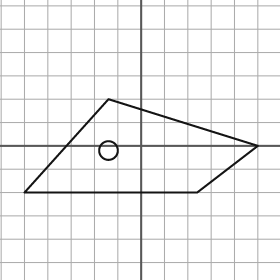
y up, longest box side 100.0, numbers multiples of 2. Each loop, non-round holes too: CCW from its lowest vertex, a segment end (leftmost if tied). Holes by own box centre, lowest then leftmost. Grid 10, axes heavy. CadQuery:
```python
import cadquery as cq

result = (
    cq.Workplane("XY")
    .moveTo(-50.0, -20.0)
    .lineTo(24.0, -20.0)
    .lineTo(50.0, 0.0)
    .lineTo(-14.0, 20.0)
    .close()
    .moveTo(-14.0, -2.0)
    .circle(4.0)
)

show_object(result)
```